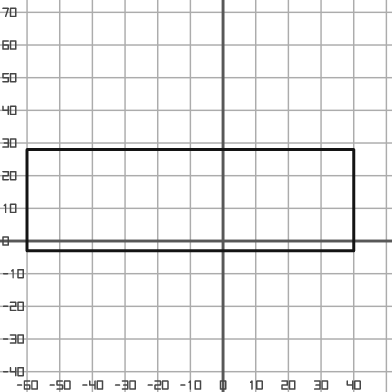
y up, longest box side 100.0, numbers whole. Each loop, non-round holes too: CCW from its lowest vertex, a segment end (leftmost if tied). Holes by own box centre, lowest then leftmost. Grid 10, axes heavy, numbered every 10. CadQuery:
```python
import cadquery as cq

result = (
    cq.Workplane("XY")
    .moveTo(-60.0, -3.0)
    .lineTo(40.0, -3.0)
    .lineTo(40.0, 28.0)
    .lineTo(-60.0, 28.0)
    .close()
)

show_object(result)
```